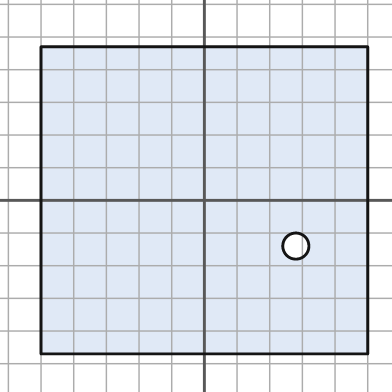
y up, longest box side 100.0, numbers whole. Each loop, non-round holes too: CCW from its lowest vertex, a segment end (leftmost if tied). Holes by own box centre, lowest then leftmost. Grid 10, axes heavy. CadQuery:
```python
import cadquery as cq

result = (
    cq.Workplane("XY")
    .moveTo(-50.0, -47.0)
    .lineTo(50.0, -47.0)
    .lineTo(50.0, 47.0)
    .lineTo(-50.0, 47.0)
    .close()
    .moveTo(28.0, -14.0)
    .circle(4.0)
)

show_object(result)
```